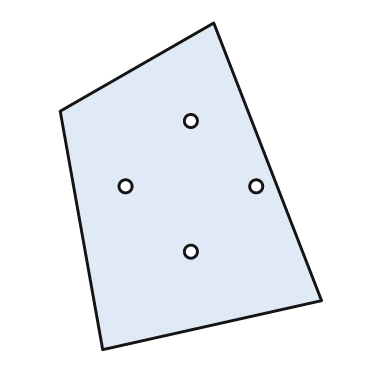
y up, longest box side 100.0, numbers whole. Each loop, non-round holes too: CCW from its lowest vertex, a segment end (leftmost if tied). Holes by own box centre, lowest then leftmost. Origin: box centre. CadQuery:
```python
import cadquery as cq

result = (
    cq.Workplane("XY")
    .moveTo(-27.0, -50.0)
    .lineTo(40.0, -35.0)
    .lineTo(7.0, 50.0)
    .lineTo(-40.0, 23.0)
    .close()
    .moveTo(0.0, -20.0)
    .circle(2.0)
    .moveTo(-20.0, 0.0)
    .circle(2.0)
    .moveTo(20.0, 0.0)
    .circle(2.0)
    .moveTo(0.0, 20.0)
    .circle(2.0)
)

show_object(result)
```